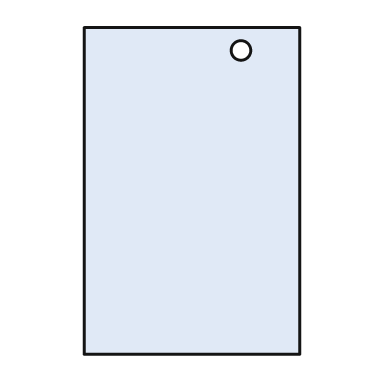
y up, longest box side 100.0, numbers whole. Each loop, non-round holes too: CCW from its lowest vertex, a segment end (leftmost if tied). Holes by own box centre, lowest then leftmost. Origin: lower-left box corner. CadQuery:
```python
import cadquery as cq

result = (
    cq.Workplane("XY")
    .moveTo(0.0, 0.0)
    .lineTo(66.0, 0.0)
    .lineTo(66.0, 100.0)
    .lineTo(0.0, 100.0)
    .close()
    .moveTo(48.0, 93.0)
    .circle(3.0)
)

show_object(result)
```